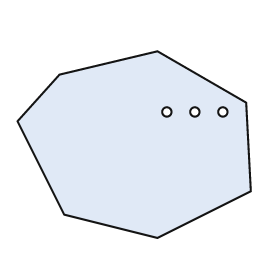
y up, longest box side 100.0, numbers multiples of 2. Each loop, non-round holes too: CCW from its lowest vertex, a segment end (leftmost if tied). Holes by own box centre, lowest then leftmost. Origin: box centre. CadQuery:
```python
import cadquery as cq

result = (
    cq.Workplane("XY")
    .moveTo(10.0, -40.0)
    .lineTo(50.0, -20.0)
    .lineTo(48.0, 18.0)
    .lineTo(10.0, 40.0)
    .lineTo(-32.0, 30.0)
    .lineTo(-50.0, 10.0)
    .lineTo(-30.0, -30.0)
    .close()
    .moveTo(14.0, 14.0)
    .circle(2.0)
    .moveTo(26.0, 14.0)
    .circle(2.0)
    .moveTo(38.0, 14.0)
    .circle(2.0)
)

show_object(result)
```